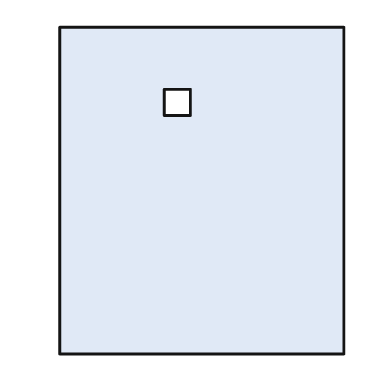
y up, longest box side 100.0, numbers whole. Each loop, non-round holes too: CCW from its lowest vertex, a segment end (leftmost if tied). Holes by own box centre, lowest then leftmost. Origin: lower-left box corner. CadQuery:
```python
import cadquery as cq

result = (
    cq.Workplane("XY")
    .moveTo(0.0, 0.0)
    .lineTo(87.0, 0.0)
    .lineTo(87.0, 100.0)
    .lineTo(0.0, 100.0)
    .close()
    .moveTo(32.0, 73.0)
    .lineTo(40.0, 73.0)
    .lineTo(40.0, 81.0)
    .lineTo(32.0, 81.0)
    .close()
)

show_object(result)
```